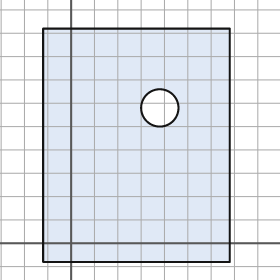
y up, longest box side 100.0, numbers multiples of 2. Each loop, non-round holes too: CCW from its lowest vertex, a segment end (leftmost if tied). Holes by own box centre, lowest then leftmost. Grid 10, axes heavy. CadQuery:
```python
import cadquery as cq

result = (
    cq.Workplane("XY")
    .moveTo(-12.0, -8.0)
    .lineTo(68.0, -8.0)
    .lineTo(68.0, 92.0)
    .lineTo(-12.0, 92.0)
    .close()
    .moveTo(38.0, 58.0)
    .circle(8.0)
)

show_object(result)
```